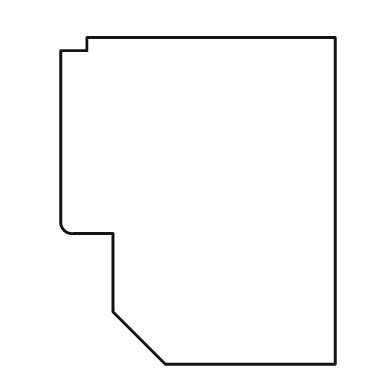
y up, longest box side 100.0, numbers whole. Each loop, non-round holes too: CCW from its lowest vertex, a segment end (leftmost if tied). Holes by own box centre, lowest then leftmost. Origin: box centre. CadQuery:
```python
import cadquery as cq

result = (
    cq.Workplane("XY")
    .moveTo(-10.0, -50.0)
    .lineTo(42.0, -50.0)
    .lineTo(42.0, 50.0)
    .lineTo(-34.0, 50.0)
    .lineTo(-34.0, 46.0)
    .lineTo(-42.0, 46.0)
    .lineTo(-42.0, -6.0)
    .threePointArc((-41.0, -9.0), (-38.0, -10.0))
    .lineTo(-26.0, -10.0)
    .lineTo(-26.0, -34.0)
    .close()
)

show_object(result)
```